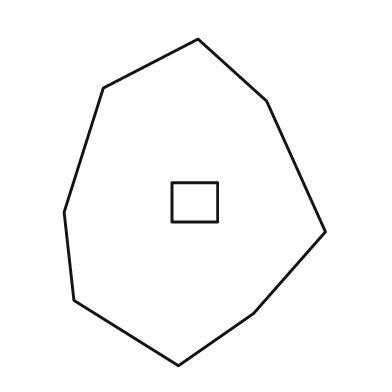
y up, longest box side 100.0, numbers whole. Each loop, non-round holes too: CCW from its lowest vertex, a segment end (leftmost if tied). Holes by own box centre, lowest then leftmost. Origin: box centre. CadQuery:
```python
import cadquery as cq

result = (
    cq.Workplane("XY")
    .moveTo(-5.0, -50.0)
    .lineTo(18.0, -34.0)
    .lineTo(40.0, -9.0)
    .lineTo(22.0, 31.0)
    .lineTo(1.0, 50.0)
    .lineTo(-28.0, 35.0)
    .lineTo(-40.0, -3.0)
    .lineTo(-37.0, -30.0)
    .close()
    .moveTo(-7.0, -6.0)
    .lineTo(7.0, -6.0)
    .lineTo(7.0, 6.0)
    .lineTo(-7.0, 6.0)
    .close()
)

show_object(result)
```